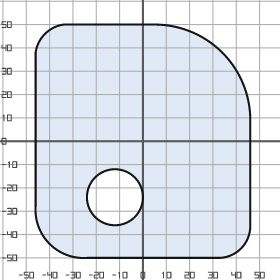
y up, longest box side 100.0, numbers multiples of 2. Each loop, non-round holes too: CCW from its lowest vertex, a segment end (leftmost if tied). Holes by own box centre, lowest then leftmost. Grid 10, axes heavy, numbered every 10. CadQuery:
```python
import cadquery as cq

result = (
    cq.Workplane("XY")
    .moveTo(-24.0, -50.0)
    .lineTo(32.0, -50.0)
    .threePointArc((42.0, -46.0), (46.0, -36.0))
    .lineTo(46.0, 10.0)
    .threePointArc((34.0, 38.0), (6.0, 50.0))
    .lineTo(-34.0, 50.0)
    .threePointArc((-42.0, 46.0), (-46.0, 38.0))
    .lineTo(-46.0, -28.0)
    .threePointArc((-40.0, -44.0), (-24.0, -50.0))
    .close()
    .moveTo(-12.0, -24.0)
    .circle(12.0)
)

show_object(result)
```